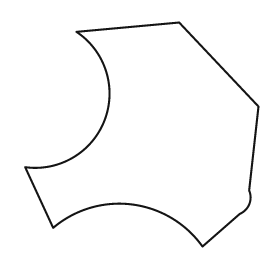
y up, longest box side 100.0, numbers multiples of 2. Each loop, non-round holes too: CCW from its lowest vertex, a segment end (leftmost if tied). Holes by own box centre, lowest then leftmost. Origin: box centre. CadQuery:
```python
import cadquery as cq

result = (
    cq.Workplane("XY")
    .moveTo(26.0, -48.0)
    .lineTo(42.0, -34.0)
    .threePointArc((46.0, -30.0), (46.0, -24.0))
    .lineTo(50.0, 12.0)
    .lineTo(16.0, 48.0)
    .lineTo(-28.0, 44.0)
    .threePointArc((-16.0, 6.0), (-50.0, -14.0))
    .lineTo(-38.0, -40.0)
    .threePointArc((-4.0, -30.0), (26.0, -48.0))
    .close()
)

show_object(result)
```